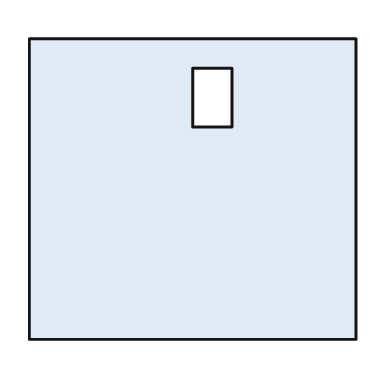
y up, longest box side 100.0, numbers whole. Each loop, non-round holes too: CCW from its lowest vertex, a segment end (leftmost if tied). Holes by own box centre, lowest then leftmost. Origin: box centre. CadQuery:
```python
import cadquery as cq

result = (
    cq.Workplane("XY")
    .moveTo(-50.0, -46.0)
    .lineTo(50.0, -46.0)
    .lineTo(50.0, 46.0)
    .lineTo(-50.0, 46.0)
    .close()
    .moveTo(0.0, 19.0)
    .lineTo(12.0, 19.0)
    .lineTo(12.0, 37.0)
    .lineTo(0.0, 37.0)
    .close()
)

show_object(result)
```